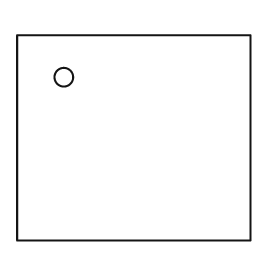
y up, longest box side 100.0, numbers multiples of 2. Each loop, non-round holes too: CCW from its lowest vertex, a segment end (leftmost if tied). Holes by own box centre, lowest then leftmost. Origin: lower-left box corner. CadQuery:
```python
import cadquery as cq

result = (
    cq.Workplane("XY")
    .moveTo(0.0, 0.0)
    .lineTo(100.0, 0.0)
    .lineTo(100.0, 88.0)
    .lineTo(0.0, 88.0)
    .close()
    .moveTo(20.0, 70.0)
    .circle(4.0)
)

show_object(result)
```